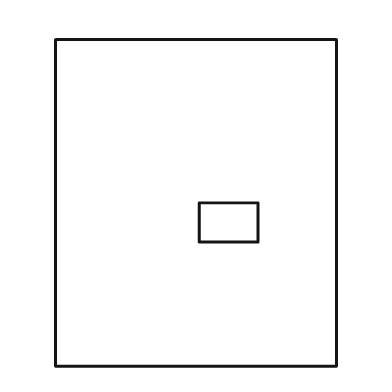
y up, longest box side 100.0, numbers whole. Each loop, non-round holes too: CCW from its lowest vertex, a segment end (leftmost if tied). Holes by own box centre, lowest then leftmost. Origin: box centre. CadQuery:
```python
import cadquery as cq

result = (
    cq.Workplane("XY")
    .moveTo(-43.0, -50.0)
    .lineTo(43.0, -50.0)
    .lineTo(43.0, 50.0)
    .lineTo(-43.0, 50.0)
    .close()
    .moveTo(1.0, -12.0)
    .lineTo(19.0, -12.0)
    .lineTo(19.0, 0.0)
    .lineTo(1.0, 0.0)
    .close()
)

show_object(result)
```